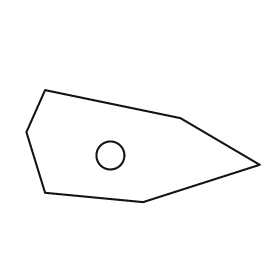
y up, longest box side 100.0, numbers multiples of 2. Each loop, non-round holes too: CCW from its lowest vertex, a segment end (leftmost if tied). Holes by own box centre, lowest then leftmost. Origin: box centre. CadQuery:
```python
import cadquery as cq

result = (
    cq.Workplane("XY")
    .moveTo(0.0, -24.0)
    .lineTo(50.0, -8.0)
    .lineTo(16.0, 12.0)
    .lineTo(-42.0, 24.0)
    .lineTo(-50.0, 6.0)
    .lineTo(-42.0, -20.0)
    .close()
    .moveTo(-14.0, -4.0)
    .circle(6.0)
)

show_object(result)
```